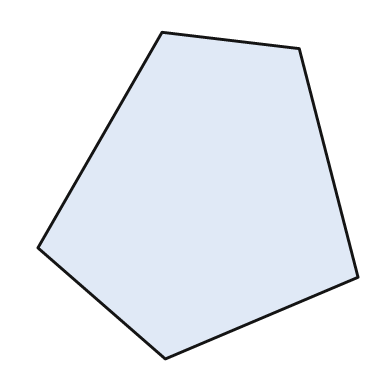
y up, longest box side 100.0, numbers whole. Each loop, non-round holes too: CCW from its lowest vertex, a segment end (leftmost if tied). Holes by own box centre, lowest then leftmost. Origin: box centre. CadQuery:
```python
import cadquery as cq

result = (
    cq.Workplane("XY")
    .moveTo(-10.0, -50.0)
    .lineTo(49.0, -25.0)
    .lineTo(31.0, 45.0)
    .lineTo(-11.0, 50.0)
    .lineTo(-49.0, -16.0)
    .close()
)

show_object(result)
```